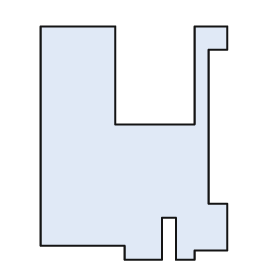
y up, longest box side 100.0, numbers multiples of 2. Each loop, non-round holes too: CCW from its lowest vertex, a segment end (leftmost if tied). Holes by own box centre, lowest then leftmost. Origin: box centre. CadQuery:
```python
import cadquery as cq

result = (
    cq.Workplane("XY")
    .moveTo(-4.0, -50.0)
    .lineTo(12.0, -50.0)
    .lineTo(12.0, -32.0)
    .lineTo(18.0, -32.0)
    .lineTo(18.0, -50.0)
    .lineTo(26.0, -50.0)
    .lineTo(26.0, -46.0)
    .lineTo(40.0, -46.0)
    .lineTo(40.0, -26.0)
    .lineTo(32.0, -26.0)
    .lineTo(32.0, 40.0)
    .lineTo(40.0, 40.0)
    .lineTo(40.0, 50.0)
    .lineTo(26.0, 50.0)
    .lineTo(26.0, 8.0)
    .lineTo(-8.0, 8.0)
    .lineTo(-8.0, 50.0)
    .lineTo(-40.0, 50.0)
    .lineTo(-40.0, -44.0)
    .lineTo(-4.0, -44.0)
    .close()
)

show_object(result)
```